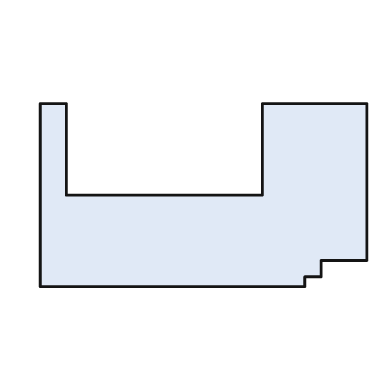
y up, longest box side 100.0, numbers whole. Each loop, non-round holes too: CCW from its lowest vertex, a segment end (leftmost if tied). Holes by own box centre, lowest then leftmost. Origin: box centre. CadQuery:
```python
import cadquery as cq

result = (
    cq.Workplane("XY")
    .moveTo(-50.0, -28.0)
    .lineTo(31.0, -28.0)
    .lineTo(31.0, -25.0)
    .lineTo(36.0, -25.0)
    .lineTo(36.0, -20.0)
    .lineTo(50.0, -20.0)
    .lineTo(50.0, 28.0)
    .lineTo(18.0, 28.0)
    .lineTo(18.0, 0.0)
    .lineTo(-42.0, 0.0)
    .lineTo(-42.0, 28.0)
    .lineTo(-50.0, 28.0)
    .close()
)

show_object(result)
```